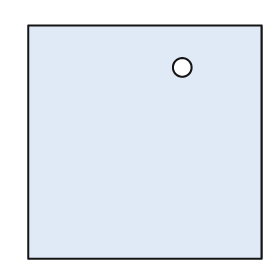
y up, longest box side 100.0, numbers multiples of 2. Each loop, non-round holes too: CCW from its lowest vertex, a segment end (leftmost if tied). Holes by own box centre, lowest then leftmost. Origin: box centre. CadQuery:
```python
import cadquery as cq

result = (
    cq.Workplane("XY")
    .moveTo(-50.0, -50.0)
    .lineTo(50.0, -50.0)
    .lineTo(50.0, 50.0)
    .lineTo(-50.0, 50.0)
    .close()
    .moveTo(16.0, 32.0)
    .circle(4.0)
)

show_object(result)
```